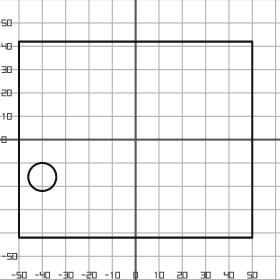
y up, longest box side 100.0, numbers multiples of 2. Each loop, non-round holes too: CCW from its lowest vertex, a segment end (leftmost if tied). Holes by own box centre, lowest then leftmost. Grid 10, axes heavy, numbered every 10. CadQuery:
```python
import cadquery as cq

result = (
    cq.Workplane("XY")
    .moveTo(-50.0, -42.0)
    .lineTo(50.0, -42.0)
    .lineTo(50.0, 42.0)
    .lineTo(-50.0, 42.0)
    .close()
    .moveTo(-40.0, -16.0)
    .circle(6.0)
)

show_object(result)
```